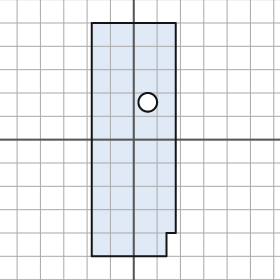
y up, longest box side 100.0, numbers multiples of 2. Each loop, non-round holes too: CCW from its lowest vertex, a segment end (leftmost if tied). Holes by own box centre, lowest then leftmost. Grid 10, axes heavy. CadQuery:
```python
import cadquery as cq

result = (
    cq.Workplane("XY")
    .moveTo(-18.0, -50.0)
    .lineTo(14.0, -50.0)
    .lineTo(14.0, -40.0)
    .lineTo(18.0, -40.0)
    .lineTo(18.0, 50.0)
    .lineTo(-18.0, 50.0)
    .close()
    .moveTo(6.0, 16.0)
    .circle(4.0)
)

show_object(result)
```